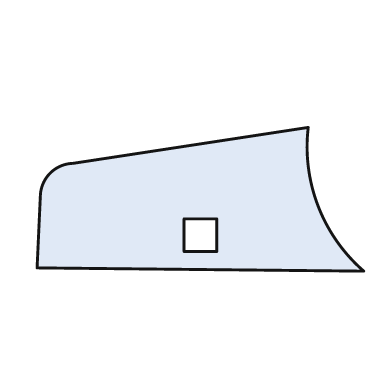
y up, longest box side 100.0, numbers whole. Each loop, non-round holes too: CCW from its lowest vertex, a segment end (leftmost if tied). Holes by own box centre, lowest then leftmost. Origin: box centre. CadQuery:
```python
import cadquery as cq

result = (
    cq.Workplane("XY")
    .moveTo(50.0, -22.0)
    .threePointArc((36.0, -2.0), (33.0, 22.0))
    .lineTo(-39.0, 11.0)
    .threePointArc((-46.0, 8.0), (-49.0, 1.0))
    .lineTo(-50.0, -21.0)
    .close()
    .moveTo(-5.0, -16.0)
    .lineTo(5.0, -16.0)
    .lineTo(5.0, -6.0)
    .lineTo(-5.0, -6.0)
    .close()
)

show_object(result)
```